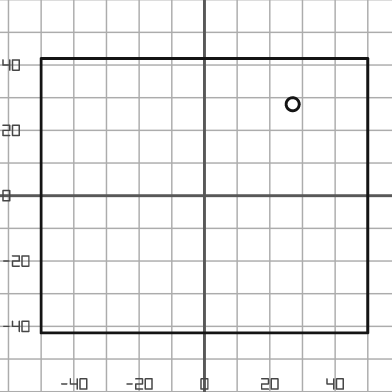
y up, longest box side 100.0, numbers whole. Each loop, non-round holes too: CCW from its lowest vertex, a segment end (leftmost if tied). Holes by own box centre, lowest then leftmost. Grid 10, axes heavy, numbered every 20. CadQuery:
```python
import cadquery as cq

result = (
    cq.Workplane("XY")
    .moveTo(-50.0, -42.0)
    .lineTo(50.0, -42.0)
    .lineTo(50.0, 42.0)
    .lineTo(-50.0, 42.0)
    .close()
    .moveTo(27.0, 28.0)
    .circle(2.0)
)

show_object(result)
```